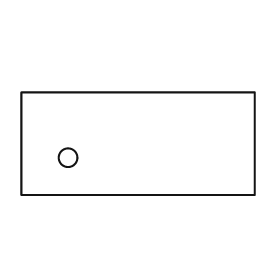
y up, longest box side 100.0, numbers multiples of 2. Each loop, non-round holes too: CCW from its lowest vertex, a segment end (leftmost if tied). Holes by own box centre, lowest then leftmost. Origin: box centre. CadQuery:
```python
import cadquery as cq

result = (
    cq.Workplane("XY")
    .moveTo(-50.0, -22.0)
    .lineTo(50.0, -22.0)
    .lineTo(50.0, 22.0)
    .lineTo(-50.0, 22.0)
    .close()
    .moveTo(-30.0, -6.0)
    .circle(4.0)
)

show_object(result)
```